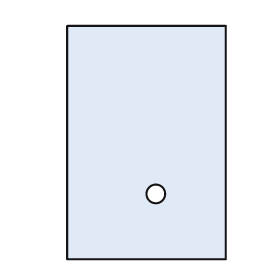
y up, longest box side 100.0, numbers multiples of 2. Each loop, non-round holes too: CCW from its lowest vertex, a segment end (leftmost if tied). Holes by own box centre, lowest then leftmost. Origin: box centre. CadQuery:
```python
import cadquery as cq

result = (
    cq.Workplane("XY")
    .moveTo(-34.0, -50.0)
    .lineTo(34.0, -50.0)
    .lineTo(34.0, 50.0)
    .lineTo(-34.0, 50.0)
    .close()
    .moveTo(4.0, -22.0)
    .circle(4.0)
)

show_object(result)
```